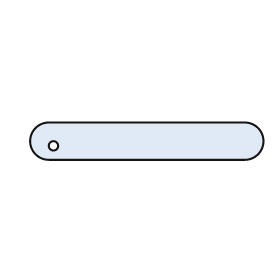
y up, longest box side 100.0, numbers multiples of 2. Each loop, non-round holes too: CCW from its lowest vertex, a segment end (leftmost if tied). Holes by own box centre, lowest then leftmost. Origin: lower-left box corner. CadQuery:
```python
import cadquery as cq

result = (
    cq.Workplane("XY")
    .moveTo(8.0, 0.0)
    .lineTo(92.0, 0.0)
    .threePointArc((100.0, 8.0), (92.0, 16.0))
    .lineTo(8.0, 16.0)
    .threePointArc((0.0, 8.0), (8.0, 0.0))
    .close()
    .moveTo(10.0, 6.0)
    .circle(2.0)
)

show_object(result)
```